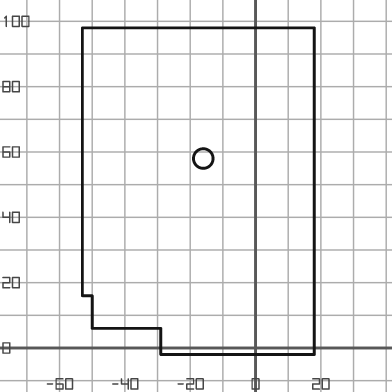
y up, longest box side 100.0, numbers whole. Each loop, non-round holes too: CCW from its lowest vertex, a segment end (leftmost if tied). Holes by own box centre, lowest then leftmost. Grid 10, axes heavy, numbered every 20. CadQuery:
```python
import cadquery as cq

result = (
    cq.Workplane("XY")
    .moveTo(-29.0, -2.0)
    .lineTo(18.0, -2.0)
    .lineTo(18.0, 98.0)
    .lineTo(-53.0, 98.0)
    .lineTo(-53.0, 16.0)
    .lineTo(-50.0, 16.0)
    .lineTo(-50.0, 6.0)
    .lineTo(-29.0, 6.0)
    .close()
    .moveTo(-16.0, 58.0)
    .circle(3.0)
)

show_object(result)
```